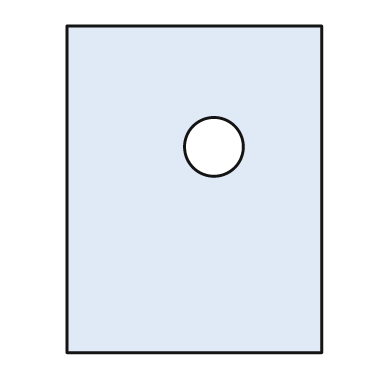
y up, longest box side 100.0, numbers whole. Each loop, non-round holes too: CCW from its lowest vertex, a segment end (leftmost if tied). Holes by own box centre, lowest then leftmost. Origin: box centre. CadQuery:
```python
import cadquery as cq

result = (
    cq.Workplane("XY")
    .moveTo(-39.0, -50.0)
    .lineTo(39.0, -50.0)
    .lineTo(39.0, 50.0)
    .lineTo(-39.0, 50.0)
    .close()
    .moveTo(6.0, 13.0)
    .circle(9.0)
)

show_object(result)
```